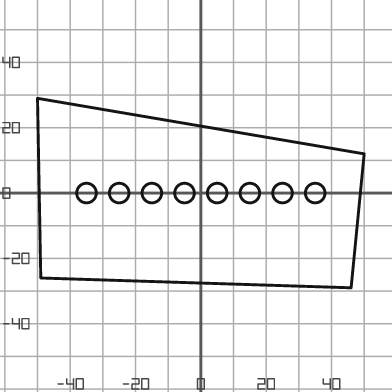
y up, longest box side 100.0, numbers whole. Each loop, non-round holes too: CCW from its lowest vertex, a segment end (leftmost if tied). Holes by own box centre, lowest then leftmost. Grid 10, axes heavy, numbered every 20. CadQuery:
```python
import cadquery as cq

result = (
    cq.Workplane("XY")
    .moveTo(46.0, -29.0)
    .lineTo(50.0, 12.0)
    .lineTo(-50.0, 29.0)
    .lineTo(-49.0, -26.0)
    .close()
    .moveTo(-35.0, 0.0)
    .circle(3.0)
    .moveTo(-25.0, 0.0)
    .circle(3.0)
    .moveTo(-15.0, 0.0)
    .circle(3.0)
    .moveTo(-5.0, 0.0)
    .circle(3.0)
    .moveTo(5.0, 0.0)
    .circle(3.0)
    .moveTo(15.0, 0.0)
    .circle(3.0)
    .moveTo(25.0, 0.0)
    .circle(3.0)
    .moveTo(35.0, 0.0)
    .circle(3.0)
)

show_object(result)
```